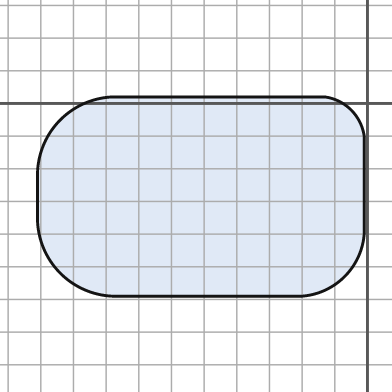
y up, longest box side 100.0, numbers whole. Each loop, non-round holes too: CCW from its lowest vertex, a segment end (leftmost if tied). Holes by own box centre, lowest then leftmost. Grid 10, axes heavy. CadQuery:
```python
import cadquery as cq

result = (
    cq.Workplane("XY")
    .moveTo(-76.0, -59.0)
    .lineTo(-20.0, -59.0)
    .threePointArc((-7.0, -53.0), (-1.0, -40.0))
    .lineTo(-1.0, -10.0)
    .threePointArc((-5.0, -2.0), (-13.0, 2.0))
    .lineTo(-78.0, 2.0)
    .threePointArc((-94.0, -5.0), (-101.0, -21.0))
    .lineTo(-101.0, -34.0)
    .threePointArc((-94.0, -52.0), (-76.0, -59.0))
    .close()
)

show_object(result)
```